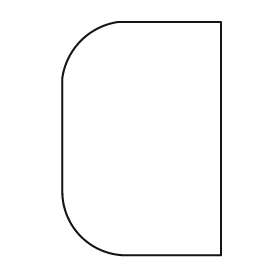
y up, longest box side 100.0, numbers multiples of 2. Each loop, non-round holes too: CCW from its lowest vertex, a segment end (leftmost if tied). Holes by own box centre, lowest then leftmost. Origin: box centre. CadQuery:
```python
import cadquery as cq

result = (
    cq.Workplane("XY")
    .moveTo(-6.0, -50.0)
    .lineTo(34.0, -50.0)
    .lineTo(34.0, 50.0)
    .lineTo(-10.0, 50.0)
    .threePointArc((-26.0, 42.0), (-34.0, 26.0))
    .lineTo(-34.0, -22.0)
    .threePointArc((-26.0, -42.0), (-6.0, -50.0))
    .close()
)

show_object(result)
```